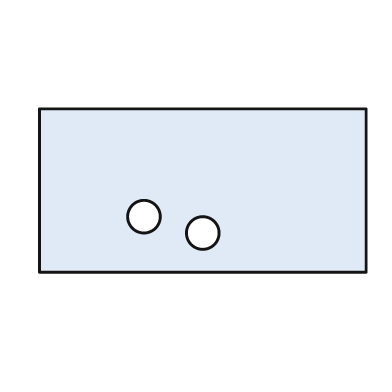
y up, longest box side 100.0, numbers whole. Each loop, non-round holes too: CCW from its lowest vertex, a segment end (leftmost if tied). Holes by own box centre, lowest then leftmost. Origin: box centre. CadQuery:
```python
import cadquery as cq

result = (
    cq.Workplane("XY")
    .moveTo(-50.0, -25.0)
    .lineTo(50.0, -25.0)
    .lineTo(50.0, 25.0)
    .lineTo(-50.0, 25.0)
    .close()
    .moveTo(0.0, -13.0)
    .circle(5.0)
    .moveTo(-18.0, -8.0)
    .circle(5.0)
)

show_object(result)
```